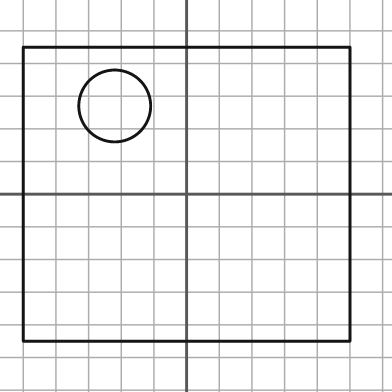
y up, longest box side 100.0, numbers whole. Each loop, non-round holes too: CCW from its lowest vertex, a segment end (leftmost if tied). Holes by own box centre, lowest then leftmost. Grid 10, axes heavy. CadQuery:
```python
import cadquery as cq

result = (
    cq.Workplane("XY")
    .moveTo(-50.0, -45.0)
    .lineTo(50.0, -45.0)
    .lineTo(50.0, 45.0)
    .lineTo(-50.0, 45.0)
    .close()
    .moveTo(-22.0, 27.0)
    .circle(11.0)
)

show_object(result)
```